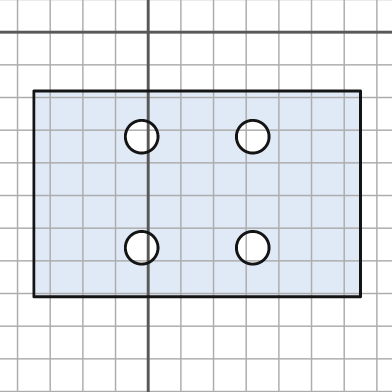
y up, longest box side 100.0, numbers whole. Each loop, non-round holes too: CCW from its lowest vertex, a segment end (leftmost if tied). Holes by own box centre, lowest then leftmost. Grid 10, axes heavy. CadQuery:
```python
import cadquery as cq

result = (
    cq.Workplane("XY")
    .moveTo(-35.0, -81.0)
    .lineTo(65.0, -81.0)
    .lineTo(65.0, -18.0)
    .lineTo(-35.0, -18.0)
    .close()
    .moveTo(-2.0, -66.0)
    .circle(5.0)
    .moveTo(32.0, -66.0)
    .circle(5.0)
    .moveTo(-2.0, -32.0)
    .circle(5.0)
    .moveTo(32.0, -32.0)
    .circle(5.0)
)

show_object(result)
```